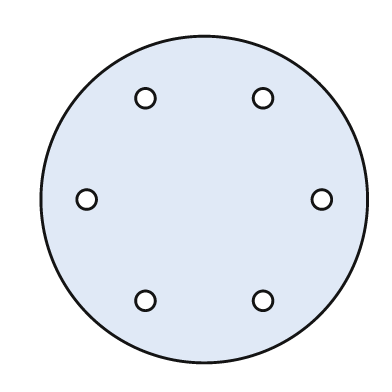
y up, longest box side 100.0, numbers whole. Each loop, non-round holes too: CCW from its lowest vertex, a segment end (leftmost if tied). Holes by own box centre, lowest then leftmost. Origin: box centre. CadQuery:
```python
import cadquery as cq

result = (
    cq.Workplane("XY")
    .moveTo(0.0, 0.0)
    .circle(50.0)
    .moveTo(-18.0, -31.0)
    .circle(3.0)
    .moveTo(18.0, -31.0)
    .circle(3.0)
    .moveTo(-36.0, 0.0)
    .circle(3.0)
    .moveTo(36.0, 0.0)
    .circle(3.0)
    .moveTo(-18.0, 31.0)
    .circle(3.0)
    .moveTo(18.0, 31.0)
    .circle(3.0)
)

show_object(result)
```